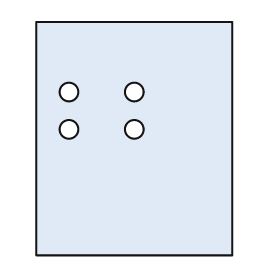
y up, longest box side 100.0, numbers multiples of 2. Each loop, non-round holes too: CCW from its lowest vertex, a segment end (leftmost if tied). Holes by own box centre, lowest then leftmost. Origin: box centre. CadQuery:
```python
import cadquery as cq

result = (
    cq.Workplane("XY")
    .moveTo(-42.0, -50.0)
    .lineTo(42.0, -50.0)
    .lineTo(42.0, 50.0)
    .lineTo(-42.0, 50.0)
    .close()
    .moveTo(-28.0, 4.0)
    .circle(4.0)
    .moveTo(0.0, 4.0)
    .circle(4.0)
    .moveTo(-28.0, 20.0)
    .circle(4.0)
    .moveTo(0.0, 20.0)
    .circle(4.0)
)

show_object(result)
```